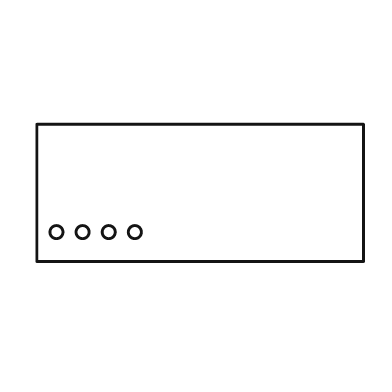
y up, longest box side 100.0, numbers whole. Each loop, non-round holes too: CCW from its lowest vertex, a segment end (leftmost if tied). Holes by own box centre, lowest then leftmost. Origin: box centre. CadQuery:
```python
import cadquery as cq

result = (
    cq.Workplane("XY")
    .moveTo(-50.0, -21.0)
    .lineTo(50.0, -21.0)
    .lineTo(50.0, 21.0)
    .lineTo(-50.0, 21.0)
    .close()
    .moveTo(-44.0, -12.0)
    .circle(2.0)
    .moveTo(-36.0, -12.0)
    .circle(2.0)
    .moveTo(-28.0, -12.0)
    .circle(2.0)
    .moveTo(-20.0, -12.0)
    .circle(2.0)
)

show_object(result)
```